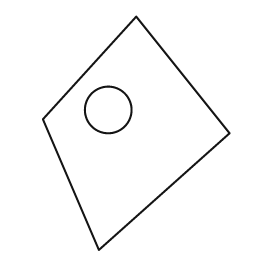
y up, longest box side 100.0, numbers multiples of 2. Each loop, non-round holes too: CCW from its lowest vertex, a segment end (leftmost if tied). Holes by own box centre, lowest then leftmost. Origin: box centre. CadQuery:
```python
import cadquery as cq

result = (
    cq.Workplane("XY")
    .moveTo(-16.0, -50.0)
    .lineTo(40.0, 0.0)
    .lineTo(0.0, 50.0)
    .lineTo(-40.0, 6.0)
    .close()
    .moveTo(-12.0, 10.0)
    .circle(10.0)
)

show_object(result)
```